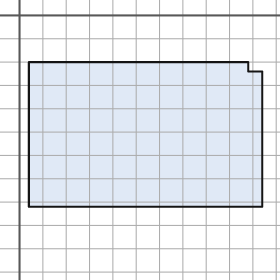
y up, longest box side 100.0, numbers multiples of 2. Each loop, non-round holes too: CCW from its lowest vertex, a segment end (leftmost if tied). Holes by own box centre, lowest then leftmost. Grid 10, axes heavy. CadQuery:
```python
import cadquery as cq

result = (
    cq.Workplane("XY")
    .moveTo(4.0, -82.0)
    .lineTo(104.0, -82.0)
    .lineTo(104.0, -24.0)
    .lineTo(98.0, -24.0)
    .lineTo(98.0, -20.0)
    .lineTo(4.0, -20.0)
    .close()
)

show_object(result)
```